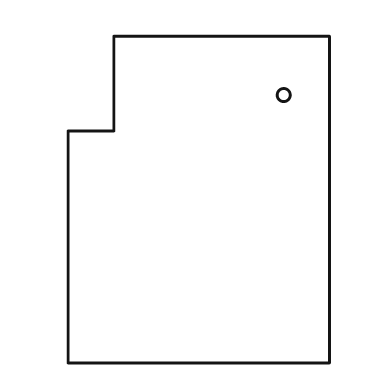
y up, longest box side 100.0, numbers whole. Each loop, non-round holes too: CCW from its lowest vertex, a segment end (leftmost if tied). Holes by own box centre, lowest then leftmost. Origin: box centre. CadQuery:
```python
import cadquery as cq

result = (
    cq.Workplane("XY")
    .moveTo(-40.0, -50.0)
    .lineTo(40.0, -50.0)
    .lineTo(40.0, 50.0)
    .lineTo(-26.0, 50.0)
    .lineTo(-26.0, 21.0)
    .lineTo(-40.0, 21.0)
    .close()
    .moveTo(26.0, 32.0)
    .circle(2.0)
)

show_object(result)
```